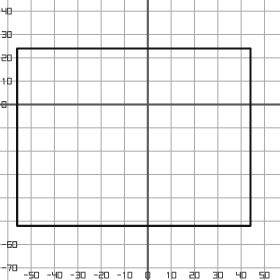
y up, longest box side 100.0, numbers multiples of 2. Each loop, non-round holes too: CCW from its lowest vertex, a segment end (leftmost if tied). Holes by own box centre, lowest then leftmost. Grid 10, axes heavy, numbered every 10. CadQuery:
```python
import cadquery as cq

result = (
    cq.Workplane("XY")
    .moveTo(-56.0, -52.0)
    .lineTo(44.0, -52.0)
    .lineTo(44.0, 24.0)
    .lineTo(-56.0, 24.0)
    .close()
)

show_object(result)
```